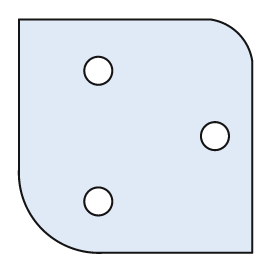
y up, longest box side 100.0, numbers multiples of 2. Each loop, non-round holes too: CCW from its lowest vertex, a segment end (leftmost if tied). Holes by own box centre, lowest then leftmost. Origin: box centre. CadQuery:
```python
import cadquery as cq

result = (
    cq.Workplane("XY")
    .moveTo(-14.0, -50.0)
    .lineTo(50.0, -50.0)
    .lineTo(50.0, 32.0)
    .threePointArc((44.0, 44.0), (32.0, 50.0))
    .lineTo(-50.0, 50.0)
    .lineTo(-50.0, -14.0)
    .threePointArc((-40.0, -40.0), (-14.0, -50.0))
    .close()
    .moveTo(-16.0, -28.0)
    .circle(6.0)
    .moveTo(34.0, 0.0)
    .circle(6.0)
    .moveTo(-16.0, 28.0)
    .circle(6.0)
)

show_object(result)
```